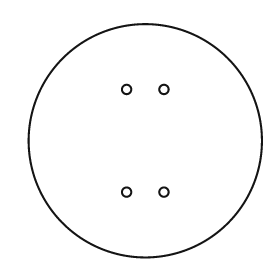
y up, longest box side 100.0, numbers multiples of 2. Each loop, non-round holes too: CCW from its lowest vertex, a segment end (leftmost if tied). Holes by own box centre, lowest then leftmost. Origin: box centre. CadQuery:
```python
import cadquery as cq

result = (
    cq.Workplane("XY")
    .moveTo(0.0, 0.0)
    .circle(50.0)
    .moveTo(-8.0, -22.0)
    .circle(2.0)
    .moveTo(8.0, -22.0)
    .circle(2.0)
    .moveTo(-8.0, 22.0)
    .circle(2.0)
    .moveTo(8.0, 22.0)
    .circle(2.0)
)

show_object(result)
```